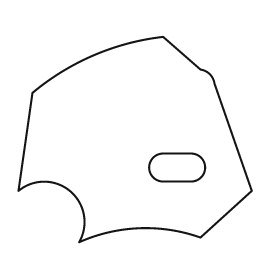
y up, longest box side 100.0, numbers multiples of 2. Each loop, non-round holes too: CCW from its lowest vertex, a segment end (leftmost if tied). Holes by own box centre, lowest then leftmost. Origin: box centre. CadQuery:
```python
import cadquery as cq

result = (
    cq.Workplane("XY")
    .moveTo(-24.0, -44.0)
    .threePointArc((2.0, -38.0), (28.0, -42.0))
    .lineTo(50.0, -22.0)
    .lineTo(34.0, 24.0)
    .threePointArc((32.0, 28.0), (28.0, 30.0))
    .lineTo(12.0, 44.0)
    .threePointArc((-18.0, 36.0), (-44.0, 20.0))
    .lineTo(-50.0, -22.0)
    .threePointArc((-28.0, -22.0), (-24.0, -44.0))
    .close()
    .moveTo(12.0, -18.0)
    .lineTo(24.0, -18.0)
    .threePointArc((30.0, -12.0), (24.0, -6.0))
    .lineTo(12.0, -6.0)
    .threePointArc((6.0, -12.0), (12.0, -18.0))
    .close()
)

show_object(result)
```